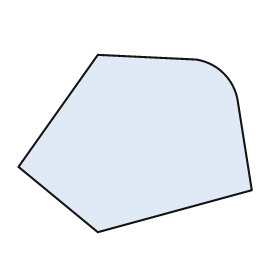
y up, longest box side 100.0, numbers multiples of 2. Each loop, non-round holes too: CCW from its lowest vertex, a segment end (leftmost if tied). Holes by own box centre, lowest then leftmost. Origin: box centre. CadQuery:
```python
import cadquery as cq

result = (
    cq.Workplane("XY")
    .moveTo(-16.0, -38.0)
    .lineTo(50.0, -20.0)
    .lineTo(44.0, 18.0)
    .threePointArc((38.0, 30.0), (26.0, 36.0))
    .lineTo(-16.0, 38.0)
    .lineTo(-50.0, -10.0)
    .close()
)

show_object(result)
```